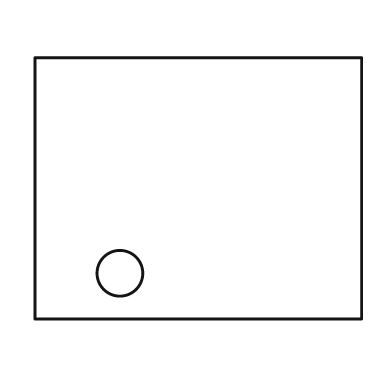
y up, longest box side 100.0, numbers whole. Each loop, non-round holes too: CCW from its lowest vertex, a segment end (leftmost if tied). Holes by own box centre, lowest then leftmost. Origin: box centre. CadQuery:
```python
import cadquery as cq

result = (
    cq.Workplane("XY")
    .moveTo(-50.0, -40.0)
    .lineTo(50.0, -40.0)
    .lineTo(50.0, 40.0)
    .lineTo(-50.0, 40.0)
    .close()
    .moveTo(-24.0, -26.0)
    .circle(7.0)
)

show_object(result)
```